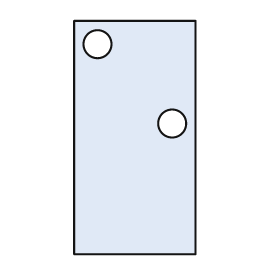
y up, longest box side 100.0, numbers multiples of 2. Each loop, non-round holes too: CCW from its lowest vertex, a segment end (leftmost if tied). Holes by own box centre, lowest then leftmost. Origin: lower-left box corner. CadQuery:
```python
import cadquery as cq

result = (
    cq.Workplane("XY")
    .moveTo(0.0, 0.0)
    .lineTo(52.0, 0.0)
    .lineTo(52.0, 100.0)
    .lineTo(0.0, 100.0)
    .close()
    .moveTo(42.0, 56.0)
    .circle(6.0)
    .moveTo(10.0, 90.0)
    .circle(6.0)
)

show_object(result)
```